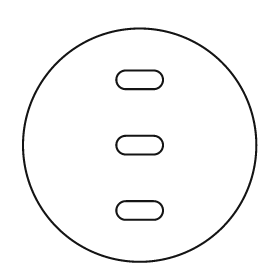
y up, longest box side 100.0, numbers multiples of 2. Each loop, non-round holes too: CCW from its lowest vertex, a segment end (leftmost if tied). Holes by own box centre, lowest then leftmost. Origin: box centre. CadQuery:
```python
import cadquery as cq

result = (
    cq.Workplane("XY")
    .moveTo(0.0, 0.0)
    .circle(50.0)
    .moveTo(-6.0, -32.0)
    .lineTo(6.0, -32.0)
    .threePointArc((10.0, -28.0), (6.0, -24.0))
    .lineTo(-6.0, -24.0)
    .threePointArc((-10.0, -28.0), (-6.0, -32.0))
    .close()
    .moveTo(-6.0, -4.0)
    .lineTo(6.0, -4.0)
    .threePointArc((10.0, 0.0), (6.0, 4.0))
    .lineTo(-6.0, 4.0)
    .threePointArc((-10.0, 0.0), (-6.0, -4.0))
    .close()
    .moveTo(-6.0, 24.0)
    .lineTo(6.0, 24.0)
    .threePointArc((10.0, 28.0), (6.0, 32.0))
    .lineTo(-6.0, 32.0)
    .threePointArc((-10.0, 28.0), (-6.0, 24.0))
    .close()
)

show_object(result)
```